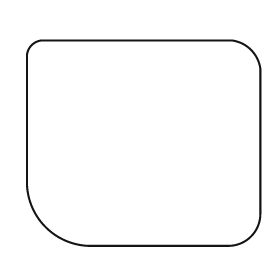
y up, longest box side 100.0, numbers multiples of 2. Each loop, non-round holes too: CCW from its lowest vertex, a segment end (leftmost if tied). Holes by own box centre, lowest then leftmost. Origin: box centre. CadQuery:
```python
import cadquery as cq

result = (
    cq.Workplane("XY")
    .moveTo(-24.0, -44.0)
    .lineTo(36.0, -44.0)
    .threePointArc((46.0, -40.0), (50.0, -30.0))
    .lineTo(50.0, 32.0)
    .threePointArc((46.0, 40.0), (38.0, 44.0))
    .lineTo(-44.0, 44.0)
    .threePointArc((-48.0, 42.0), (-50.0, 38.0))
    .lineTo(-50.0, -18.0)
    .threePointArc((-42.0, -36.0), (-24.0, -44.0))
    .close()
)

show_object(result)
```